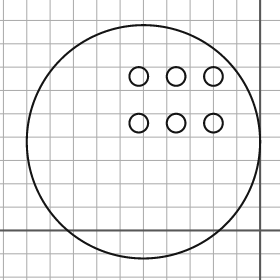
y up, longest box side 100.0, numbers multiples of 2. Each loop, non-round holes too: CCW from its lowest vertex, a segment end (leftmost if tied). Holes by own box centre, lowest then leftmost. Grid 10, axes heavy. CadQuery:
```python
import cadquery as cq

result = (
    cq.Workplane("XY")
    .moveTo(-50.0, 38.0)
    .circle(50.0)
    .moveTo(-52.0, 46.0)
    .circle(4.0)
    .moveTo(-36.0, 46.0)
    .circle(4.0)
    .moveTo(-20.0, 46.0)
    .circle(4.0)
    .moveTo(-52.0, 66.0)
    .circle(4.0)
    .moveTo(-36.0, 66.0)
    .circle(4.0)
    .moveTo(-20.0, 66.0)
    .circle(4.0)
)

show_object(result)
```